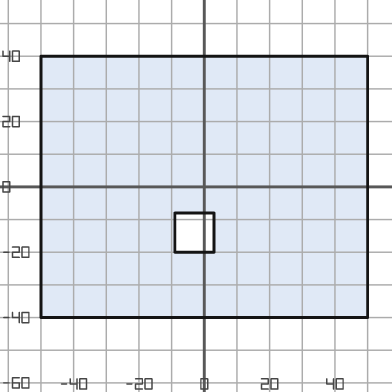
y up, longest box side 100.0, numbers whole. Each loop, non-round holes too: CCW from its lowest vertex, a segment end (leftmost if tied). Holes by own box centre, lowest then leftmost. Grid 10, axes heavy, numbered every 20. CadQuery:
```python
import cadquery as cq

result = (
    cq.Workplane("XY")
    .moveTo(-50.0, -40.0)
    .lineTo(50.0, -40.0)
    .lineTo(50.0, 40.0)
    .lineTo(-50.0, 40.0)
    .close()
    .moveTo(-9.0, -20.0)
    .lineTo(3.0, -20.0)
    .lineTo(3.0, -8.0)
    .lineTo(-9.0, -8.0)
    .close()
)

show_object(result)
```